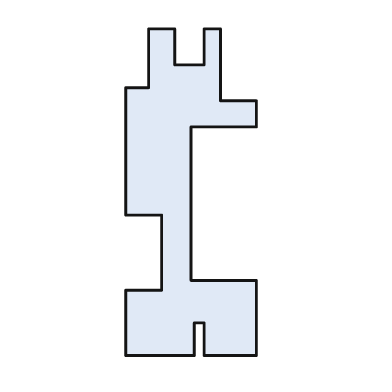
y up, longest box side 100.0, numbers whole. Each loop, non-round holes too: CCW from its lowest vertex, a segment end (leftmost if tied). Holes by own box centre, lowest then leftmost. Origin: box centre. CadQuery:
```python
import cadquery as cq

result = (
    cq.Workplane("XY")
    .moveTo(-20.0, -50.0)
    .lineTo(1.0, -50.0)
    .lineTo(1.0, -40.0)
    .lineTo(4.0, -40.0)
    .lineTo(4.0, -50.0)
    .lineTo(20.0, -50.0)
    .lineTo(20.0, -27.0)
    .lineTo(0.0, -27.0)
    .lineTo(0.0, 20.0)
    .lineTo(20.0, 20.0)
    .lineTo(20.0, 28.0)
    .lineTo(9.0, 28.0)
    .lineTo(9.0, 50.0)
    .lineTo(4.0, 50.0)
    .lineTo(4.0, 39.0)
    .lineTo(-5.0, 39.0)
    .lineTo(-5.0, 50.0)
    .lineTo(-13.0, 50.0)
    .lineTo(-13.0, 32.0)
    .lineTo(-20.0, 32.0)
    .lineTo(-20.0, -7.0)
    .lineTo(-9.0, -7.0)
    .lineTo(-9.0, -30.0)
    .lineTo(-20.0, -30.0)
    .close()
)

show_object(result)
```